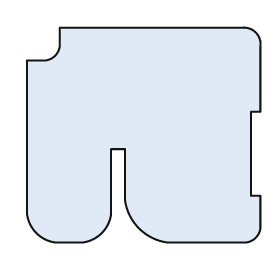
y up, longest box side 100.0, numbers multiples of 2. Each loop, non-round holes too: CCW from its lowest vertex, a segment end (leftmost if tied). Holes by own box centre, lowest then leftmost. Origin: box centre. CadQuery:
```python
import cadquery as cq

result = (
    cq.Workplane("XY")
    .moveTo(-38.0, -46.0)
    .lineTo(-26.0, -46.0)
    .threePointArc((-18.0, -42.0), (-14.0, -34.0))
    .lineTo(-14.0, -6.0)
    .lineTo(-8.0, -6.0)
    .lineTo(-8.0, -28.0)
    .threePointArc((-2.0, -40.0), (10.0, -46.0))
    .lineTo(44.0, -46.0)
    .threePointArc((48.0, -44.0), (50.0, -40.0))
    .lineTo(50.0, -26.0)
    .lineTo(46.0, -26.0)
    .lineTo(46.0, 10.0)
    .lineTo(50.0, 10.0)
    .lineTo(50.0, 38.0)
    .threePointArc((48.0, 44.0), (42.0, 46.0))
    .lineTo(-36.0, 46.0)
    .lineTo(-36.0, 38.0)
    .threePointArc((-38.0, 34.0), (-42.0, 32.0))
    .lineTo(-50.0, 32.0)
    .lineTo(-50.0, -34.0)
    .threePointArc((-46.0, -42.0), (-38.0, -46.0))
    .close()
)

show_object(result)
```